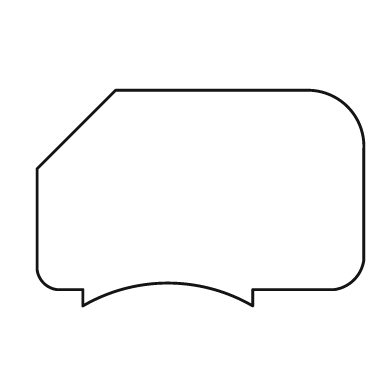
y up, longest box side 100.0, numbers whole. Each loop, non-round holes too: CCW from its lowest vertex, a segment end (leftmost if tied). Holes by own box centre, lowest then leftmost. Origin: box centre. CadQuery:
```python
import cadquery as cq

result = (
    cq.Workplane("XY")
    .moveTo(-36.0, -33.0)
    .threePointArc((-10.0, -26.0), (16.0, -33.0))
    .lineTo(16.0, -28.0)
    .lineTo(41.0, -28.0)
    .threePointArc((47.0, -25.0), (50.0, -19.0))
    .lineTo(50.0, 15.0)
    .threePointArc((45.0, 28.0), (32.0, 33.0))
    .lineTo(-26.0, 33.0)
    .lineTo(-50.0, 9.0)
    .lineTo(-50.0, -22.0)
    .threePointArc((-48.0, -26.0), (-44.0, -28.0))
    .lineTo(-36.0, -28.0)
    .close()
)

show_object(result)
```